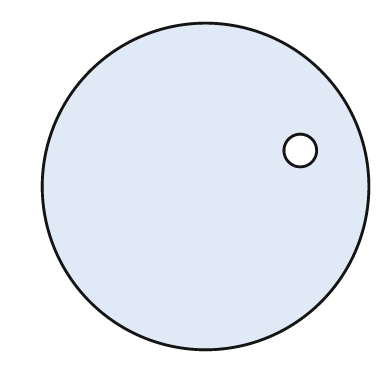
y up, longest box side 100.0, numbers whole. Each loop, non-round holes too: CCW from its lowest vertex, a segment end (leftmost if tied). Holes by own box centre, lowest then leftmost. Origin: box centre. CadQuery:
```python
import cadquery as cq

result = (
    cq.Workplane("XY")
    .moveTo(0.0, 0.0)
    .circle(50.0)
    .moveTo(29.0, 11.0)
    .circle(5.0)
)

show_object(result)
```